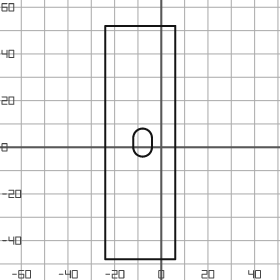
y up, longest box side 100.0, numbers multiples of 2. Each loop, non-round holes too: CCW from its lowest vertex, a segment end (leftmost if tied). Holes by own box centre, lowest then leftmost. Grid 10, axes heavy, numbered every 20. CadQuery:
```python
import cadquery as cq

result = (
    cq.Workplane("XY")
    .moveTo(-24.0, -48.0)
    .lineTo(6.0, -48.0)
    .lineTo(6.0, 52.0)
    .lineTo(-24.0, 52.0)
    .close()
    .moveTo(-12.0, 0.0)
    .threePointArc((-8.0, -4.0), (-4.0, 0.0))
    .lineTo(-4.0, 4.0)
    .threePointArc((-8.0, 8.0), (-12.0, 4.0))
    .close()
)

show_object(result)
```